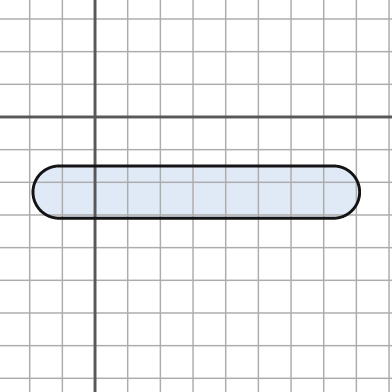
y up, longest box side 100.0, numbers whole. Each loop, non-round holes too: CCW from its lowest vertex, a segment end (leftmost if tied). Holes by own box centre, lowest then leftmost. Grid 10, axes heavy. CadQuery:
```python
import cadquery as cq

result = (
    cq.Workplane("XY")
    .moveTo(-11.0, -31.0)
    .lineTo(73.0, -31.0)
    .threePointArc((81.0, -23.0), (73.0, -15.0))
    .lineTo(-11.0, -15.0)
    .threePointArc((-19.0, -23.0), (-11.0, -31.0))
    .close()
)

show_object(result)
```